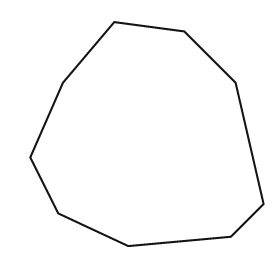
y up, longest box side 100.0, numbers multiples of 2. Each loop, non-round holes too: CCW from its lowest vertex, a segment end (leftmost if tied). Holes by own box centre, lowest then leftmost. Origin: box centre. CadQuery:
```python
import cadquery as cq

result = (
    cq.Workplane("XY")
    .moveTo(-8.0, -48.0)
    .lineTo(36.0, -44.0)
    .lineTo(50.0, -30.0)
    .lineTo(38.0, 22.0)
    .lineTo(16.0, 44.0)
    .lineTo(-14.0, 48.0)
    .lineTo(-36.0, 22.0)
    .lineTo(-50.0, -10.0)
    .lineTo(-38.0, -34.0)
    .close()
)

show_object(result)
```